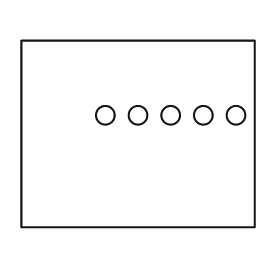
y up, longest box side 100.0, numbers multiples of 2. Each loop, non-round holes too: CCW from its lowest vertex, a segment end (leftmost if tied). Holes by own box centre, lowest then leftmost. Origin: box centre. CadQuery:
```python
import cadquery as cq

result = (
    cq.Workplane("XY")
    .moveTo(-50.0, -40.0)
    .lineTo(50.0, -40.0)
    .lineTo(50.0, 40.0)
    .lineTo(-50.0, 40.0)
    .close()
    .moveTo(-14.0, 8.0)
    .circle(4.0)
    .moveTo(0.0, 8.0)
    .circle(4.0)
    .moveTo(14.0, 8.0)
    .circle(4.0)
    .moveTo(28.0, 8.0)
    .circle(4.0)
    .moveTo(42.0, 8.0)
    .circle(4.0)
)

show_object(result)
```